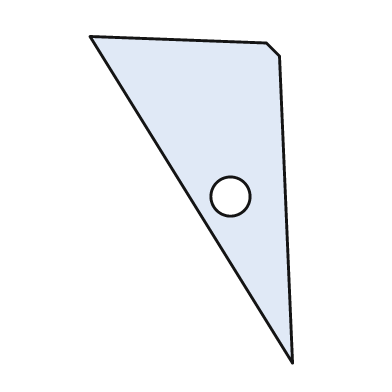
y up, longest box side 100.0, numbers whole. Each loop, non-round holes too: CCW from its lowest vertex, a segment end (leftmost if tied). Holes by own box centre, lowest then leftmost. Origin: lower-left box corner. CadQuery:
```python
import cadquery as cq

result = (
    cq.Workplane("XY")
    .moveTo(62.0, 0.0)
    .lineTo(58.0, 94.0)
    .lineTo(54.0, 98.0)
    .lineTo(0.0, 100.0)
    .close()
    .moveTo(43.0, 51.0)
    .circle(6.0)
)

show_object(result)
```